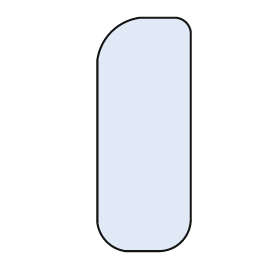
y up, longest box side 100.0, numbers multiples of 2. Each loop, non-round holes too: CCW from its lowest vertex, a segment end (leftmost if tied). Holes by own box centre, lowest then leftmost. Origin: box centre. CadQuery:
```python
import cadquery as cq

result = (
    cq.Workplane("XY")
    .moveTo(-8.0, -50.0)
    .lineTo(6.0, -50.0)
    .threePointArc((16.0, -46.0), (20.0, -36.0))
    .lineTo(20.0, 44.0)
    .threePointArc((18.0, 48.0), (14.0, 50.0))
    .lineTo(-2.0, 50.0)
    .threePointArc((-14.0, 44.0), (-20.0, 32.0))
    .lineTo(-20.0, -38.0)
    .threePointArc((-16.0, -46.0), (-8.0, -50.0))
    .close()
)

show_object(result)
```